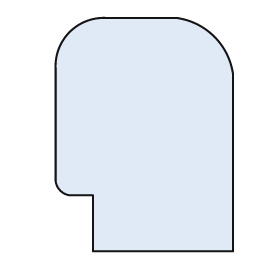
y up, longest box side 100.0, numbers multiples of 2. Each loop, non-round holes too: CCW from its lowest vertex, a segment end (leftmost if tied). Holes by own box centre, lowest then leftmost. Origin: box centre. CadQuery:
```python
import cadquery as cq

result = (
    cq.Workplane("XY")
    .moveTo(-22.0, -50.0)
    .lineTo(38.0, -50.0)
    .lineTo(38.0, 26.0)
    .threePointArc((30.0, 42.0), (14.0, 50.0))
    .lineTo(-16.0, 50.0)
    .threePointArc((-32.0, 44.0), (-38.0, 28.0))
    .lineTo(-38.0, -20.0)
    .threePointArc((-36.0, -24.0), (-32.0, -26.0))
    .lineTo(-22.0, -26.0)
    .close()
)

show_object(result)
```